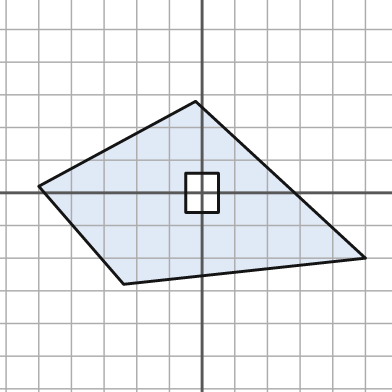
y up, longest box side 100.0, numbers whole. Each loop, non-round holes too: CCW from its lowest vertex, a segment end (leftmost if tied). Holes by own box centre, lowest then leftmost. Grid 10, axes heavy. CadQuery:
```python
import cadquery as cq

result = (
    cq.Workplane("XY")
    .moveTo(-24.0, -28.0)
    .lineTo(50.0, -20.0)
    .lineTo(-2.0, 28.0)
    .lineTo(-50.0, 2.0)
    .close()
    .moveTo(-5.0, -6.0)
    .lineTo(5.0, -6.0)
    .lineTo(5.0, 6.0)
    .lineTo(-5.0, 6.0)
    .close()
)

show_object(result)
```